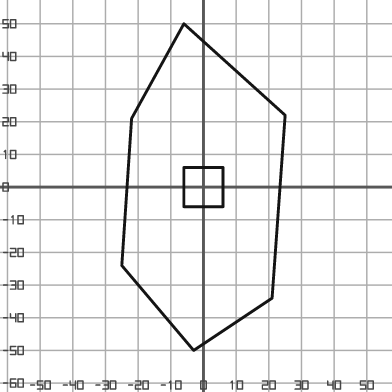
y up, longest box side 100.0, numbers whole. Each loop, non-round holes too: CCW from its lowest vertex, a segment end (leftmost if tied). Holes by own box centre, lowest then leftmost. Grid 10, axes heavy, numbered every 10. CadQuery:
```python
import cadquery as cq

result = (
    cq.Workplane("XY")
    .moveTo(-3.0, -50.0)
    .lineTo(21.0, -34.0)
    .lineTo(25.0, 22.0)
    .lineTo(-6.0, 50.0)
    .lineTo(-22.0, 21.0)
    .lineTo(-25.0, -24.0)
    .close()
    .moveTo(-6.0, -6.0)
    .lineTo(6.0, -6.0)
    .lineTo(6.0, 6.0)
    .lineTo(-6.0, 6.0)
    .close()
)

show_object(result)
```